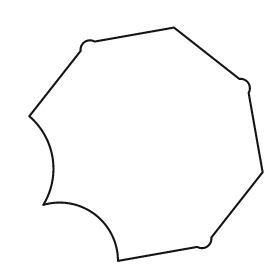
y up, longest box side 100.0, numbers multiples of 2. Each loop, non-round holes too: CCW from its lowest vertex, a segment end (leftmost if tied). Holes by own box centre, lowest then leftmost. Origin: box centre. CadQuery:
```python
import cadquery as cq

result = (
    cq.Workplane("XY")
    .moveTo(-12.0, -50.0)
    .lineTo(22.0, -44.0)
    .threePointArc((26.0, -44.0), (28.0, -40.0))
    .lineTo(50.0, -12.0)
    .lineTo(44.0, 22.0)
    .threePointArc((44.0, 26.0), (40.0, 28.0))
    .lineTo(12.0, 50.0)
    .lineTo(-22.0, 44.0)
    .threePointArc((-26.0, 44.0), (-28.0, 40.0))
    .lineTo(-50.0, 12.0)
    .threePointArc((-40.0, -6.0), (-44.0, -26.0))
    .threePointArc((-22.0, -30.0), (-12.0, -50.0))
    .close()
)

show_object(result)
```